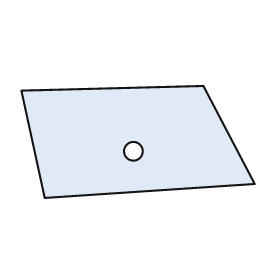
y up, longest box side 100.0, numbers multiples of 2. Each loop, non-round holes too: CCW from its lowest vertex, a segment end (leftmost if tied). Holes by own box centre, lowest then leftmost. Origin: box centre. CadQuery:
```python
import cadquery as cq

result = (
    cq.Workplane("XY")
    .moveTo(-40.0, -24.0)
    .lineTo(50.0, -18.0)
    .lineTo(28.0, 24.0)
    .lineTo(-50.0, 22.0)
    .close()
    .moveTo(-2.0, -4.0)
    .circle(4.0)
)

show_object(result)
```